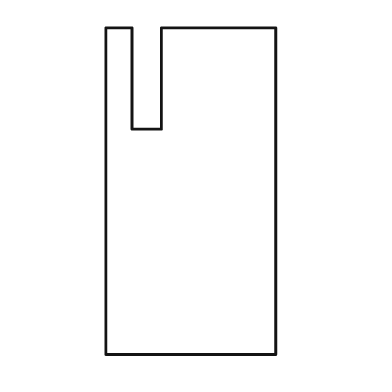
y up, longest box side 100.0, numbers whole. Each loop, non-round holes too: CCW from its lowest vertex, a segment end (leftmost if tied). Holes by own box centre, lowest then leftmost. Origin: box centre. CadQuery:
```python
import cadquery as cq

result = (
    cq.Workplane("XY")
    .moveTo(-26.0, -50.0)
    .lineTo(26.0, -50.0)
    .lineTo(26.0, 50.0)
    .lineTo(-9.0, 50.0)
    .lineTo(-9.0, 19.0)
    .lineTo(-18.0, 19.0)
    .lineTo(-18.0, 50.0)
    .lineTo(-26.0, 50.0)
    .close()
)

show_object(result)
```